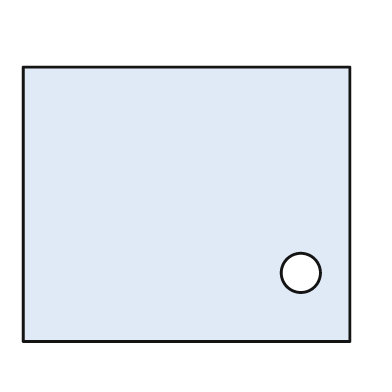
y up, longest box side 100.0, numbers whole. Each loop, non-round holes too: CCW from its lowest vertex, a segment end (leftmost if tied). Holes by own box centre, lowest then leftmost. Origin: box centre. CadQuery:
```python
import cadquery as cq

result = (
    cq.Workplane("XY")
    .moveTo(-50.0, -42.0)
    .lineTo(50.0, -42.0)
    .lineTo(50.0, 42.0)
    .lineTo(-50.0, 42.0)
    .close()
    .moveTo(35.0, -21.0)
    .circle(6.0)
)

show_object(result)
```